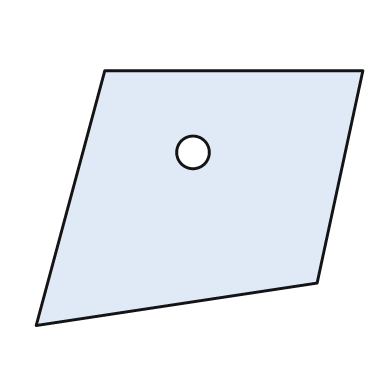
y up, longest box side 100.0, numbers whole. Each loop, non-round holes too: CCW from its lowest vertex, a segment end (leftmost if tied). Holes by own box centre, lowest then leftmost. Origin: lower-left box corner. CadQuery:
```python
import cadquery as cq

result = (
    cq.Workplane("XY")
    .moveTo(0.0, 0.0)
    .lineTo(86.0, 13.0)
    .lineTo(100.0, 78.0)
    .lineTo(21.0, 78.0)
    .close()
    .moveTo(48.0, 53.0)
    .circle(5.0)
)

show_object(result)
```